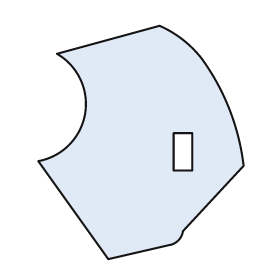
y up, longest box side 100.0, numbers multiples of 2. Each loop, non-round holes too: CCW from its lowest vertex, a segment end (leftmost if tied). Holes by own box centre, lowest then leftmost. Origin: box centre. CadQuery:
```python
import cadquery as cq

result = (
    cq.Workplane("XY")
    .moveTo(-14.0, -50.0)
    .lineTo(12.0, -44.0)
    .threePointArc((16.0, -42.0), (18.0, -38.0))
    .lineTo(44.0, -10.0)
    .threePointArc((38.0, 14.0), (26.0, 36.0))
    .threePointArc((18.0, 44.0), (8.0, 50.0))
    .lineTo(-36.0, 38.0)
    .threePointArc((-24.0, 12.0), (-44.0, -8.0))
    .close()
    .moveTo(14.0, -12.0)
    .lineTo(22.0, -12.0)
    .lineTo(22.0, 4.0)
    .lineTo(14.0, 4.0)
    .close()
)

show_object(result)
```